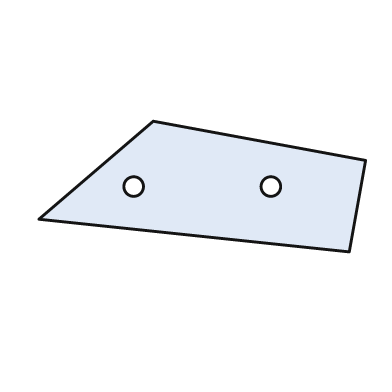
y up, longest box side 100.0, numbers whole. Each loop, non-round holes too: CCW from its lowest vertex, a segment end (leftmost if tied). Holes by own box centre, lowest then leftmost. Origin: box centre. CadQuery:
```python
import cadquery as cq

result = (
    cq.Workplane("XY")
    .moveTo(45.0, -20.0)
    .lineTo(50.0, 8.0)
    .lineTo(-15.0, 20.0)
    .lineTo(-50.0, -10.0)
    .close()
    .moveTo(-21.0, 0.0)
    .circle(3.0)
    .moveTo(21.0, 0.0)
    .circle(3.0)
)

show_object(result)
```